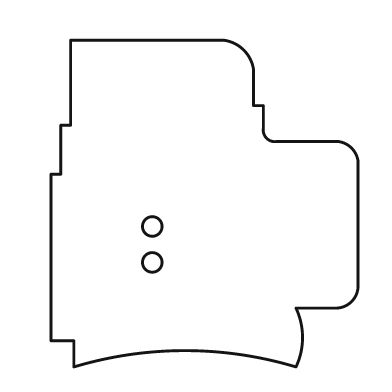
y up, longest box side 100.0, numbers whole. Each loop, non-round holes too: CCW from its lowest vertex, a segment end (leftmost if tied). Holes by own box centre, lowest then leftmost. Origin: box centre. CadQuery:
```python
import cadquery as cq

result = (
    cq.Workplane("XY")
    .moveTo(-40.0, -50.0)
    .threePointArc((-6.0, -45.0), (28.0, -50.0))
    .threePointArc((30.0, -41.0), (28.0, -32.0))
    .lineTo(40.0, -32.0)
    .threePointArc((45.0, -30.0), (47.0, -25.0))
    .lineTo(47.0, 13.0)
    .threePointArc((45.0, 17.0), (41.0, 19.0))
    .lineTo(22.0, 19.0)
    .threePointArc((19.0, 20.0), (18.0, 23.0))
    .lineTo(18.0, 30.0)
    .lineTo(15.0, 30.0)
    .lineTo(15.0, 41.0)
    .threePointArc((12.0, 47.0), (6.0, 50.0))
    .lineTo(-41.0, 50.0)
    .lineTo(-41.0, 24.0)
    .lineTo(-44.0, 24.0)
    .lineTo(-44.0, 9.0)
    .lineTo(-47.0, 9.0)
    .lineTo(-47.0, -42.0)
    .lineTo(-40.0, -42.0)
    .close()
    .moveTo(-16.0, -18.0)
    .circle(3.0)
    .moveTo(-16.0, -7.0)
    .circle(3.0)
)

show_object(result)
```